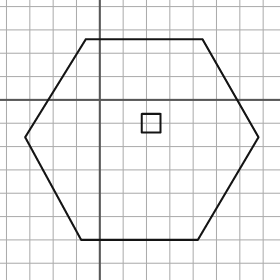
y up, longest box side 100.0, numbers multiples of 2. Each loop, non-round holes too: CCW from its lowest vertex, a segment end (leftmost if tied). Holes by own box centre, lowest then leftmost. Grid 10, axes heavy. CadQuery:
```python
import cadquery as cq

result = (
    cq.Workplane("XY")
    .moveTo(-8.0, -60.0)
    .lineTo(42.0, -60.0)
    .lineTo(68.0, -16.0)
    .lineTo(44.0, 26.0)
    .lineTo(-6.0, 26.0)
    .lineTo(-32.0, -16.0)
    .close()
    .moveTo(18.0, -14.0)
    .lineTo(26.0, -14.0)
    .lineTo(26.0, -6.0)
    .lineTo(18.0, -6.0)
    .close()
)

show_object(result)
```